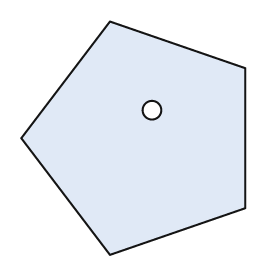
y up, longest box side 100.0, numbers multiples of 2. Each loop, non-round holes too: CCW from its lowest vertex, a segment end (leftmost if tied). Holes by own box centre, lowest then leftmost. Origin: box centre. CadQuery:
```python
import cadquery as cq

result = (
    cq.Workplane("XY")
    .moveTo(-10.0, -50.0)
    .lineTo(48.0, -30.0)
    .lineTo(48.0, 30.0)
    .lineTo(-10.0, 50.0)
    .lineTo(-48.0, 0.0)
    .close()
    .moveTo(8.0, 12.0)
    .circle(4.0)
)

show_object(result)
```